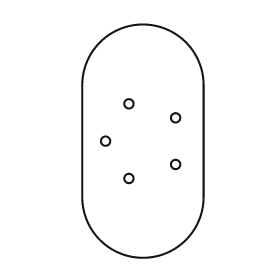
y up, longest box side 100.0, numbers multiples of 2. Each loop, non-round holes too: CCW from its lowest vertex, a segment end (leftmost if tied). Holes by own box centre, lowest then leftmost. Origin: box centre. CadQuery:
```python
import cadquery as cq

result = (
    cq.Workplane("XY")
    .moveTo(-26.0, -24.0)
    .threePointArc((0.0, -50.0), (26.0, -24.0))
    .lineTo(26.0, 24.0)
    .threePointArc((0.0, 50.0), (-26.0, 24.0))
    .close()
    .moveTo(-6.0, -16.0)
    .circle(2.0)
    .moveTo(14.0, -10.0)
    .circle(2.0)
    .moveTo(-16.0, 0.0)
    .circle(2.0)
    .moveTo(14.0, 10.0)
    .circle(2.0)
    .moveTo(-6.0, 16.0)
    .circle(2.0)
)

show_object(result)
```